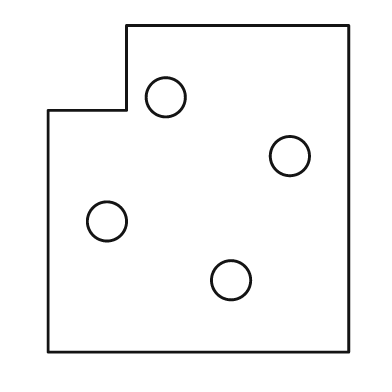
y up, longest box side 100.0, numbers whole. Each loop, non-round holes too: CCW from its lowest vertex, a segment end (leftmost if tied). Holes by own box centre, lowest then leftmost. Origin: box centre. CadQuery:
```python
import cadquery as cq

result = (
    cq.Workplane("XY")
    .moveTo(-46.0, -50.0)
    .lineTo(46.0, -50.0)
    .lineTo(46.0, 50.0)
    .lineTo(-22.0, 50.0)
    .lineTo(-22.0, 24.0)
    .lineTo(-46.0, 24.0)
    .close()
    .moveTo(10.0, -28.0)
    .circle(6.0)
    .moveTo(-28.0, -10.0)
    .circle(6.0)
    .moveTo(28.0, 10.0)
    .circle(6.0)
    .moveTo(-10.0, 28.0)
    .circle(6.0)
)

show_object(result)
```